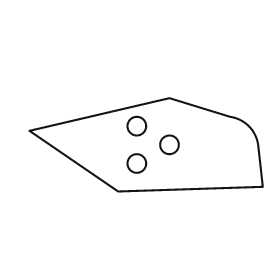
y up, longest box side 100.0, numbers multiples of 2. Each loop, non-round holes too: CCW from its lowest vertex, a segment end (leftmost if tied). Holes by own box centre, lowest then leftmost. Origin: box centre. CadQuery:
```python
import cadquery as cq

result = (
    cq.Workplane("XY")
    .moveTo(-12.0, -20.0)
    .lineTo(50.0, -18.0)
    .lineTo(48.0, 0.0)
    .threePointArc((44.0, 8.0), (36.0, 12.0))
    .lineTo(10.0, 20.0)
    .lineTo(-50.0, 6.0)
    .close()
    .moveTo(-4.0, -8.0)
    .circle(4.0)
    .moveTo(10.0, 0.0)
    .circle(4.0)
    .moveTo(-4.0, 8.0)
    .circle(4.0)
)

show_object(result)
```